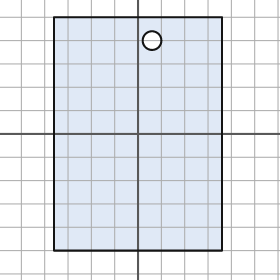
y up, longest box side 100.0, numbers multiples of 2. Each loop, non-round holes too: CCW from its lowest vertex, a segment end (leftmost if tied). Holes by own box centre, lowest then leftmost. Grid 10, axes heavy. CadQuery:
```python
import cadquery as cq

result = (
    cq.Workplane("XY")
    .moveTo(-36.0, -50.0)
    .lineTo(36.0, -50.0)
    .lineTo(36.0, 50.0)
    .lineTo(-36.0, 50.0)
    .close()
    .moveTo(6.0, 40.0)
    .circle(4.0)
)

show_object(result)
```